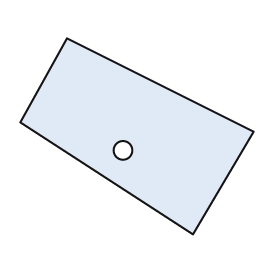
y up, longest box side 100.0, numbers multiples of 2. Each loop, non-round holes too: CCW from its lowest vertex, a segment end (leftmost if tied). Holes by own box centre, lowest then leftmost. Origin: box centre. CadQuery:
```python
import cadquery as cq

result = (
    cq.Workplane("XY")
    .moveTo(24.0, -42.0)
    .lineTo(50.0, 2.0)
    .lineTo(-30.0, 42.0)
    .lineTo(-50.0, 6.0)
    .close()
    .moveTo(-6.0, -6.0)
    .circle(4.0)
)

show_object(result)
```